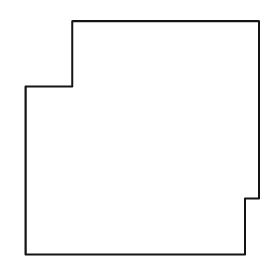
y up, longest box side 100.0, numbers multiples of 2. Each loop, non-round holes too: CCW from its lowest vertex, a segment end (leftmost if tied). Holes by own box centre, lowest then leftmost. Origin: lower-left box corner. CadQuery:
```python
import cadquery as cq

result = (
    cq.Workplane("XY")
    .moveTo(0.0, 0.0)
    .lineTo(94.0, 0.0)
    .lineTo(94.0, 24.0)
    .lineTo(100.0, 24.0)
    .lineTo(100.0, 100.0)
    .lineTo(20.0, 100.0)
    .lineTo(20.0, 72.0)
    .lineTo(0.0, 72.0)
    .close()
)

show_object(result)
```